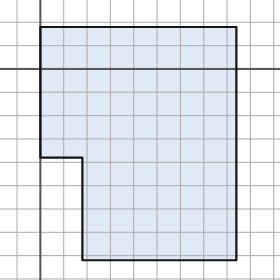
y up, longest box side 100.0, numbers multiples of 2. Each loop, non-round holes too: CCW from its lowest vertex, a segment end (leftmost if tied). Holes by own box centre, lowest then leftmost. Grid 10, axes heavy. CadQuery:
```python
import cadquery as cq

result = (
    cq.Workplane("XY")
    .moveTo(18.0, -82.0)
    .lineTo(84.0, -82.0)
    .lineTo(84.0, 18.0)
    .lineTo(0.0, 18.0)
    .lineTo(0.0, -38.0)
    .lineTo(18.0, -38.0)
    .close()
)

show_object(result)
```